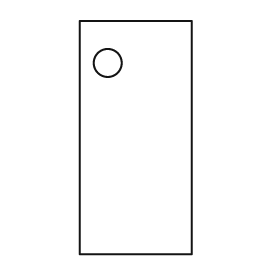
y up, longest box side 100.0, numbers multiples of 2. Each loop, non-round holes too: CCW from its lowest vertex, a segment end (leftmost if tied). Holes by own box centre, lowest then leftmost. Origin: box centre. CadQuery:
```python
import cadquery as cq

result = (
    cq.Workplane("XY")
    .moveTo(-24.0, -50.0)
    .lineTo(24.0, -50.0)
    .lineTo(24.0, 50.0)
    .lineTo(-24.0, 50.0)
    .close()
    .moveTo(-12.0, 32.0)
    .circle(6.0)
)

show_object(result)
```